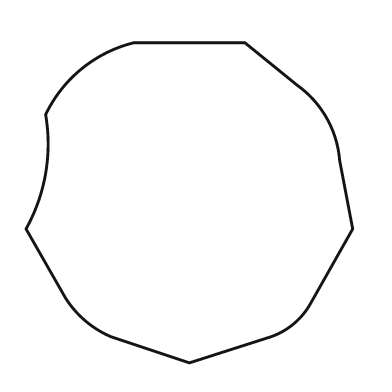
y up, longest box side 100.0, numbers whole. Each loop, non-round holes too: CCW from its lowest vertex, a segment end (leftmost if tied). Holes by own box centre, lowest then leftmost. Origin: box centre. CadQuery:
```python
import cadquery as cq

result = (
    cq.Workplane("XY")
    .moveTo(0.0, -49.0)
    .lineTo(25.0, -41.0)
    .threePointArc((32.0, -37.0), (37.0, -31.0))
    .lineTo(50.0, -8.0)
    .lineTo(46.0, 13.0)
    .threePointArc((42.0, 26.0), (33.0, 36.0))
    .lineTo(17.0, 49.0)
    .lineTo(-17.0, 49.0)
    .threePointArc((-33.0, 41.0), (-44.0, 27.0))
    .threePointArc((-44.0, 9.0), (-50.0, -8.0))
    .lineTo(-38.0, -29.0)
    .threePointArc((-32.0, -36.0), (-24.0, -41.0))
    .close()
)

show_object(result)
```